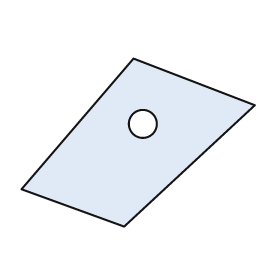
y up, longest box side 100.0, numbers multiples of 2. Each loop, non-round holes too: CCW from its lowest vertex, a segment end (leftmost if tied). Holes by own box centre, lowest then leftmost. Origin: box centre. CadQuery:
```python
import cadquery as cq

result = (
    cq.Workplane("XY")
    .moveTo(-6.0, -36.0)
    .lineTo(50.0, 16.0)
    .lineTo(-2.0, 36.0)
    .lineTo(-50.0, -20.0)
    .close()
    .moveTo(2.0, 8.0)
    .circle(6.0)
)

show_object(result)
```